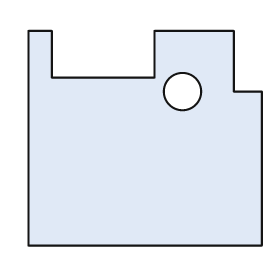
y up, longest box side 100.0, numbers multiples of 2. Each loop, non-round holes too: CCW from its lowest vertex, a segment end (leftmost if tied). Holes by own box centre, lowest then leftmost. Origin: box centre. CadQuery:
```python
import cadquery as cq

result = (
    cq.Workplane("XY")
    .moveTo(-50.0, -46.0)
    .lineTo(50.0, -46.0)
    .lineTo(50.0, 20.0)
    .lineTo(38.0, 20.0)
    .lineTo(38.0, 46.0)
    .lineTo(4.0, 46.0)
    .lineTo(4.0, 26.0)
    .lineTo(-40.0, 26.0)
    .lineTo(-40.0, 46.0)
    .lineTo(-50.0, 46.0)
    .close()
    .moveTo(16.0, 20.0)
    .circle(8.0)
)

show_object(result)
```